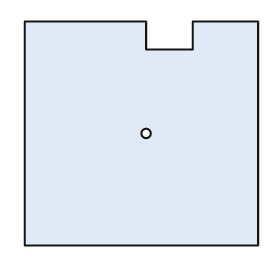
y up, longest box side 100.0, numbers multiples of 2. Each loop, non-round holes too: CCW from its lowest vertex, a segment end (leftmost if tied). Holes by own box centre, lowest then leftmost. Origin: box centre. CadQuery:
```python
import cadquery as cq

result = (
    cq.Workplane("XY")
    .moveTo(-50.0, -48.0)
    .lineTo(50.0, -48.0)
    .lineTo(50.0, 48.0)
    .lineTo(22.0, 48.0)
    .lineTo(22.0, 36.0)
    .lineTo(2.0, 36.0)
    .lineTo(2.0, 48.0)
    .lineTo(-50.0, 48.0)
    .close()
    .moveTo(2.0, 0.0)
    .circle(2.0)
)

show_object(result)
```